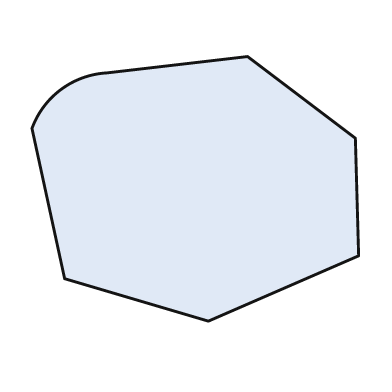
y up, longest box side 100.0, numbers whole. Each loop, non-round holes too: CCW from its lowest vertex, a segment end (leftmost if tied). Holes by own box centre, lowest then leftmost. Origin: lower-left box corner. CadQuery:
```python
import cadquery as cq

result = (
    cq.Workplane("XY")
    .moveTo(54.0, 0.0)
    .lineTo(100.0, 20.0)
    .lineTo(99.0, 56.0)
    .lineTo(66.0, 81.0)
    .lineTo(23.0, 76.0)
    .threePointArc((9.0, 71.0), (0.0, 59.0))
    .lineTo(10.0, 13.0)
    .close()
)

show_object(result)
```